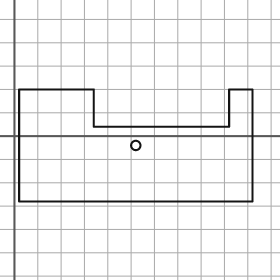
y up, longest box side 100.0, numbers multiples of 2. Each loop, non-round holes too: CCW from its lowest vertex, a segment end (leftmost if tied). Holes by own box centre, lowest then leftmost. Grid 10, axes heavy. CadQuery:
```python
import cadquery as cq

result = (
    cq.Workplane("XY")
    .moveTo(2.0, -28.0)
    .lineTo(102.0, -28.0)
    .lineTo(102.0, 20.0)
    .lineTo(92.0, 20.0)
    .lineTo(92.0, 4.0)
    .lineTo(34.0, 4.0)
    .lineTo(34.0, 20.0)
    .lineTo(2.0, 20.0)
    .close()
    .moveTo(52.0, -4.0)
    .circle(2.0)
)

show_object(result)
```